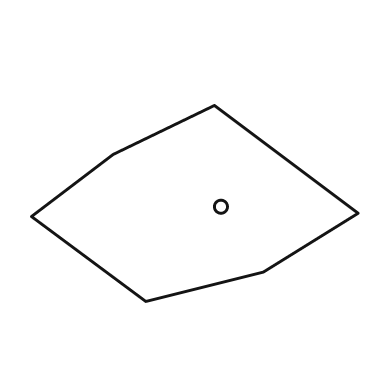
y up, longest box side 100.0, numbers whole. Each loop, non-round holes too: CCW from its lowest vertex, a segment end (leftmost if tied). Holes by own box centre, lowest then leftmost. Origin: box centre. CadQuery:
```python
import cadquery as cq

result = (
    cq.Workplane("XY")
    .moveTo(-15.0, -30.0)
    .lineTo(21.0, -21.0)
    .lineTo(50.0, -3.0)
    .lineTo(6.0, 30.0)
    .lineTo(-25.0, 15.0)
    .lineTo(-50.0, -4.0)
    .close()
    .moveTo(8.0, -1.0)
    .circle(2.0)
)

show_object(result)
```